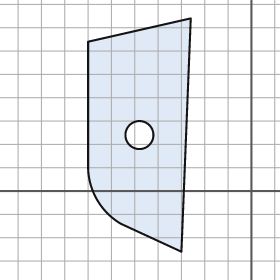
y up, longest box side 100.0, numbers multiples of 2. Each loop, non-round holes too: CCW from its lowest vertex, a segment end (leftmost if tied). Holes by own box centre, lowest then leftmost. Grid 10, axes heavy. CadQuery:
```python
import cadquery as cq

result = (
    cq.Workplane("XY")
    .moveTo(-30.0, -26.0)
    .lineTo(-26.0, 74.0)
    .lineTo(-70.0, 64.0)
    .lineTo(-70.0, 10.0)
    .threePointArc((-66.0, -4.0), (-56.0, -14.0))
    .close()
    .moveTo(-48.0, 24.0)
    .circle(6.0)
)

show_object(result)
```